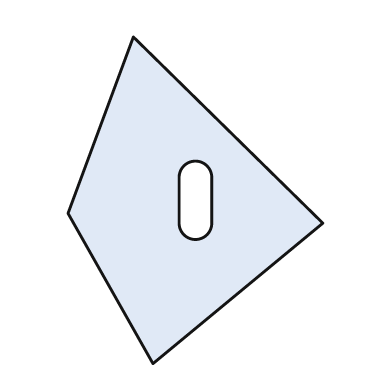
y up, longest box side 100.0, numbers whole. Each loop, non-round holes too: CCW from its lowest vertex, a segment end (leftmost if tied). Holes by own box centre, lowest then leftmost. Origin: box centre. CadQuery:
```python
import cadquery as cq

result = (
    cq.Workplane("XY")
    .moveTo(-13.0, -50.0)
    .lineTo(39.0, -7.0)
    .lineTo(-19.0, 50.0)
    .lineTo(-39.0, -4.0)
    .close()
    .moveTo(-5.0, -7.0)
    .threePointArc((0.0, -12.0), (5.0, -7.0))
    .lineTo(5.0, 7.0)
    .threePointArc((0.0, 12.0), (-5.0, 7.0))
    .close()
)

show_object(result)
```